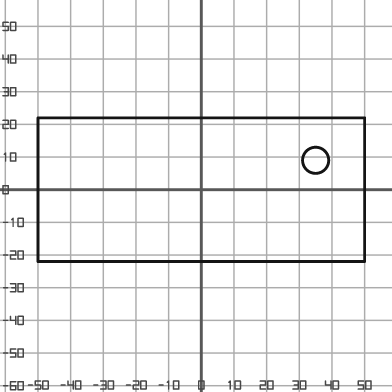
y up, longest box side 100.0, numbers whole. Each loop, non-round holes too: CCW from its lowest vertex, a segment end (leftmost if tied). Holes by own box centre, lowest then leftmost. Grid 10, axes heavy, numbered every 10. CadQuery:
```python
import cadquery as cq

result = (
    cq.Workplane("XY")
    .moveTo(-50.0, -22.0)
    .lineTo(50.0, -22.0)
    .lineTo(50.0, 22.0)
    .lineTo(-50.0, 22.0)
    .close()
    .moveTo(35.0, 9.0)
    .circle(4.0)
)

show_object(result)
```